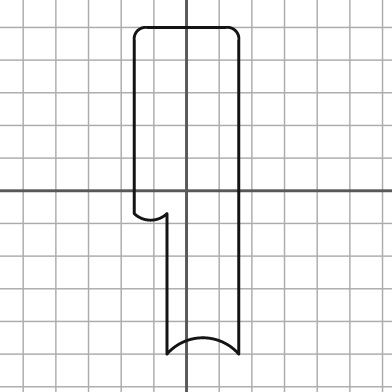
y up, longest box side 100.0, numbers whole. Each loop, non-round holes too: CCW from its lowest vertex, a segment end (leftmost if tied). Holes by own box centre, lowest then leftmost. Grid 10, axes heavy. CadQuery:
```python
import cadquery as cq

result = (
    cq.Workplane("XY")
    .moveTo(-6.0, -50.0)
    .threePointArc((5.0, -45.0), (16.0, -50.0))
    .lineTo(16.0, 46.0)
    .threePointArc((15.0, 49.0), (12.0, 50.0))
    .lineTo(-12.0, 50.0)
    .threePointArc((-15.0, 49.0), (-16.0, 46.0))
    .lineTo(-16.0, -7.0)
    .threePointArc((-11.0, -9.0), (-6.0, -7.0))
    .close()
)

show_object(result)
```